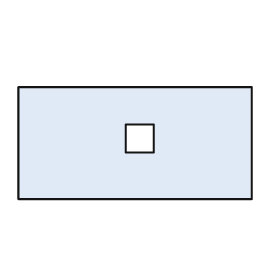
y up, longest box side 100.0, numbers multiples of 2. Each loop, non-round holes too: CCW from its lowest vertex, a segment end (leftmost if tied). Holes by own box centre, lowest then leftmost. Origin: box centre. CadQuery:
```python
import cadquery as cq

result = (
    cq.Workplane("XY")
    .moveTo(-50.0, -24.0)
    .lineTo(50.0, -24.0)
    .lineTo(50.0, 24.0)
    .lineTo(-50.0, 24.0)
    .close()
    .moveTo(-4.0, -4.0)
    .lineTo(8.0, -4.0)
    .lineTo(8.0, 8.0)
    .lineTo(-4.0, 8.0)
    .close()
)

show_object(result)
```